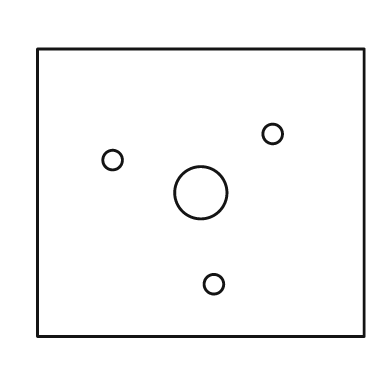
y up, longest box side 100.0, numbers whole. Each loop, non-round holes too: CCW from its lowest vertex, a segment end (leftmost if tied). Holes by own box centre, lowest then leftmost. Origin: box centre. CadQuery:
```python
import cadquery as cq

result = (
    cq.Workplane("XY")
    .moveTo(-50.0, -44.0)
    .lineTo(50.0, -44.0)
    .lineTo(50.0, 44.0)
    .lineTo(-50.0, 44.0)
    .close()
    .moveTo(4.0, -28.0)
    .circle(3.0)
    .moveTo(0.0, 0.0)
    .circle(8.0)
    .moveTo(-27.0, 10.0)
    .circle(3.0)
    .moveTo(22.0, 18.0)
    .circle(3.0)
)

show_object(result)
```